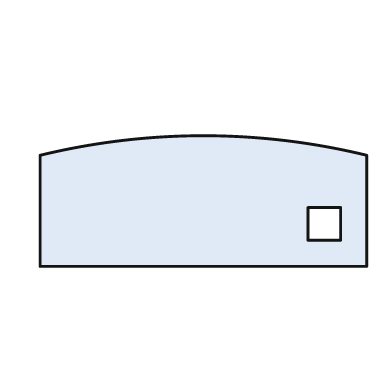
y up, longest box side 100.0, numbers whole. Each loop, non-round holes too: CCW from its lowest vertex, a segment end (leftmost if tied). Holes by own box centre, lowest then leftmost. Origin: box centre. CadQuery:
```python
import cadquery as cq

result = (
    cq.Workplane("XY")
    .moveTo(-50.0, -20.0)
    .lineTo(50.0, -20.0)
    .lineTo(50.0, 14.0)
    .threePointArc((0.0, 20.0), (-50.0, 14.0))
    .close()
    .moveTo(32.0, -12.0)
    .lineTo(42.0, -12.0)
    .lineTo(42.0, -2.0)
    .lineTo(32.0, -2.0)
    .close()
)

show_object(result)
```